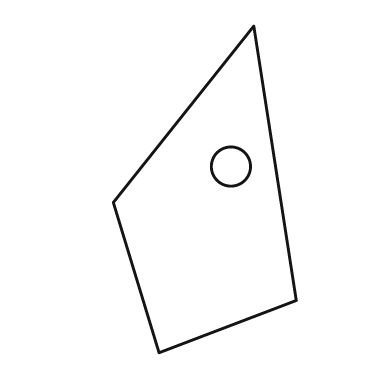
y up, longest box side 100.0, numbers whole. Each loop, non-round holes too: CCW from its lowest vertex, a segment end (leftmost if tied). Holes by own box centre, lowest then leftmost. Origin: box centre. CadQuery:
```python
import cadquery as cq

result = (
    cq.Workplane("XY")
    .moveTo(-14.0, -50.0)
    .lineTo(28.0, -34.0)
    .lineTo(15.0, 50.0)
    .lineTo(-28.0, -4.0)
    .close()
    .moveTo(8.0, 7.0)
    .circle(6.0)
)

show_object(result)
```